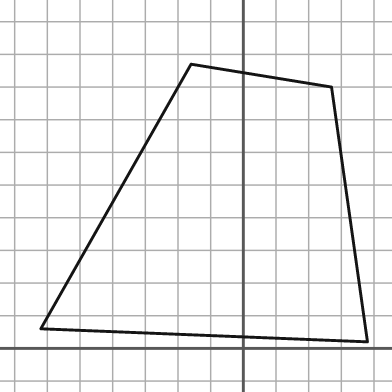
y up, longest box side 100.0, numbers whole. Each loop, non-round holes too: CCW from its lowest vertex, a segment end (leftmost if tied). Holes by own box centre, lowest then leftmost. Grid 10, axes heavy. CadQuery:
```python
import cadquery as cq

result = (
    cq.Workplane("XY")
    .moveTo(38.0, 2.0)
    .lineTo(27.0, 80.0)
    .lineTo(-16.0, 87.0)
    .lineTo(-62.0, 6.0)
    .close()
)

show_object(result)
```